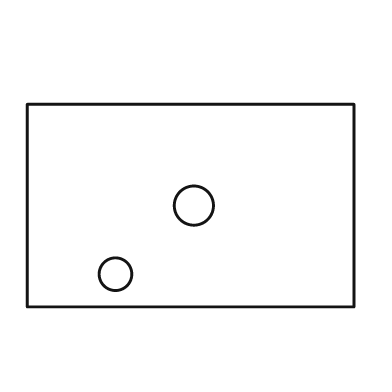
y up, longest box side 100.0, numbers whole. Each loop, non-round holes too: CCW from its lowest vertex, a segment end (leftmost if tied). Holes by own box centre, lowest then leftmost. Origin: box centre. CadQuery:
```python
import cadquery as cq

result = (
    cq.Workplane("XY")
    .moveTo(-50.0, -31.0)
    .lineTo(50.0, -31.0)
    .lineTo(50.0, 31.0)
    .lineTo(-50.0, 31.0)
    .close()
    .moveTo(-23.0, -21.0)
    .circle(5.0)
    .moveTo(1.0, 0.0)
    .circle(6.0)
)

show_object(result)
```